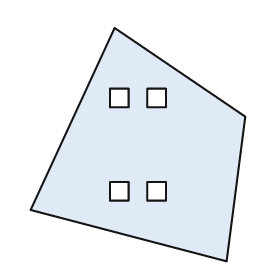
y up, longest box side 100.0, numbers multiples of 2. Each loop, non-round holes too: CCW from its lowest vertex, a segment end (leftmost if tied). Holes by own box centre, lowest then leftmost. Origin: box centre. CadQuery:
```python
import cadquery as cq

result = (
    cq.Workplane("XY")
    .moveTo(38.0, -50.0)
    .lineTo(46.0, 12.0)
    .lineTo(-10.0, 50.0)
    .lineTo(-46.0, -28.0)
    .close()
    .moveTo(-12.0, -24.0)
    .lineTo(-4.0, -24.0)
    .lineTo(-4.0, -16.0)
    .lineTo(-12.0, -16.0)
    .close()
    .moveTo(4.0, -24.0)
    .lineTo(12.0, -24.0)
    .lineTo(12.0, -16.0)
    .lineTo(4.0, -16.0)
    .close()
    .moveTo(-12.0, 16.0)
    .lineTo(-4.0, 16.0)
    .lineTo(-4.0, 24.0)
    .lineTo(-12.0, 24.0)
    .close()
    .moveTo(4.0, 16.0)
    .lineTo(12.0, 16.0)
    .lineTo(12.0, 24.0)
    .lineTo(4.0, 24.0)
    .close()
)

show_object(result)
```